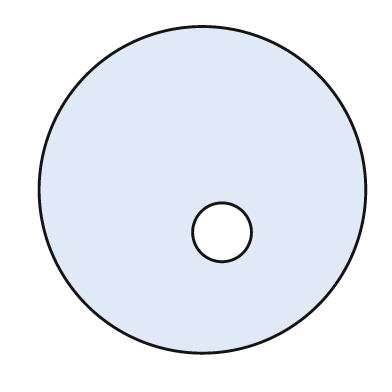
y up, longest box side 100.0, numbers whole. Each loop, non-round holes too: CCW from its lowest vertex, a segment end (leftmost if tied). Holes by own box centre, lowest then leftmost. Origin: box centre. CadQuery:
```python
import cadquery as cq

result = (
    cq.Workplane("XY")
    .moveTo(0.0, 0.0)
    .circle(50.0)
    .moveTo(6.0, -13.0)
    .circle(9.0)
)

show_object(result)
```